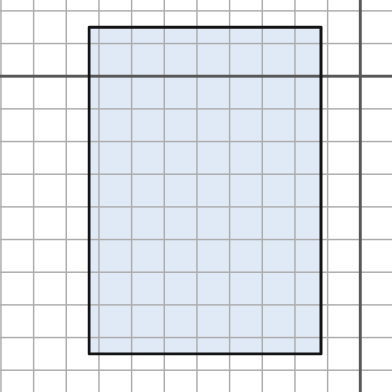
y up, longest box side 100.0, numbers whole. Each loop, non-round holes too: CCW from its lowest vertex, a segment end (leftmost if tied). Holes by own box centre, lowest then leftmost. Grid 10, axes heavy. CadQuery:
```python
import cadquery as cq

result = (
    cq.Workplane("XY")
    .moveTo(-83.0, -85.0)
    .lineTo(-12.0, -85.0)
    .lineTo(-12.0, 15.0)
    .lineTo(-83.0, 15.0)
    .close()
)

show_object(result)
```